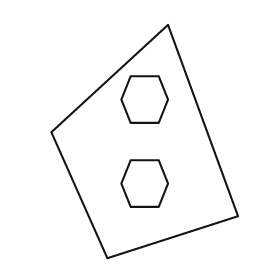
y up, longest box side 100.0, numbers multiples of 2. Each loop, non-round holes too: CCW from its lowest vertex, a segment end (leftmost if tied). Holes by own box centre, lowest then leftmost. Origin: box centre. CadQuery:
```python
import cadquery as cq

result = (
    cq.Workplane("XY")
    .moveTo(-16.0, -50.0)
    .lineTo(40.0, -32.0)
    .lineTo(10.0, 50.0)
    .lineTo(-40.0, 4.0)
    .close()
    .moveTo(-6.0, -28.0)
    .lineTo(6.0, -28.0)
    .lineTo(10.0, -18.0)
    .lineTo(6.0, -8.0)
    .lineTo(-6.0, -8.0)
    .lineTo(-10.0, -18.0)
    .close()
    .moveTo(-6.0, 8.0)
    .lineTo(6.0, 8.0)
    .lineTo(10.0, 18.0)
    .lineTo(6.0, 28.0)
    .lineTo(-6.0, 28.0)
    .lineTo(-10.0, 18.0)
    .close()
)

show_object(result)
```